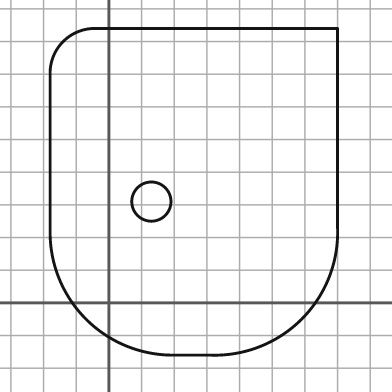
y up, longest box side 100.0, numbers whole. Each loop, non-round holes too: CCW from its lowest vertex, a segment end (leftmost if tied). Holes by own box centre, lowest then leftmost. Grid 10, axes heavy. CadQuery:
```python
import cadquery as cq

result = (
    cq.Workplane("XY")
    .moveTo(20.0, -16.0)
    .lineTo(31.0, -16.0)
    .threePointArc((59.0, -5.0), (70.0, 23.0))
    .lineTo(70.0, 84.0)
    .lineTo(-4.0, 84.0)
    .threePointArc((-14.0, 80.0), (-18.0, 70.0))
    .lineTo(-18.0, 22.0)
    .threePointArc((-7.0, -5.0), (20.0, -16.0))
    .close()
    .moveTo(13.0, 31.0)
    .circle(6.0)
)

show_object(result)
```